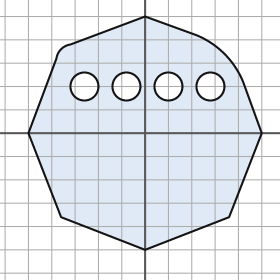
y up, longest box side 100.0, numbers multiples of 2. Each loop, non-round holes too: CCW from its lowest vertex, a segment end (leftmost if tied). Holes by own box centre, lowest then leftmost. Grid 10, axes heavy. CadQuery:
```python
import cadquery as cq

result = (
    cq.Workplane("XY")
    .moveTo(0.0, -50.0)
    .lineTo(36.0, -36.0)
    .lineTo(50.0, 0.0)
    .lineTo(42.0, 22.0)
    .threePointArc((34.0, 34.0), (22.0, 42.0))
    .lineTo(0.0, 50.0)
    .lineTo(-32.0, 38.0)
    .threePointArc((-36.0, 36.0), (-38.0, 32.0))
    .lineTo(-50.0, 0.0)
    .lineTo(-36.0, -36.0)
    .close()
    .moveTo(-26.0, 20.0)
    .circle(6.0)
    .moveTo(-8.0, 20.0)
    .circle(6.0)
    .moveTo(10.0, 20.0)
    .circle(6.0)
    .moveTo(28.0, 20.0)
    .circle(6.0)
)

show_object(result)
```